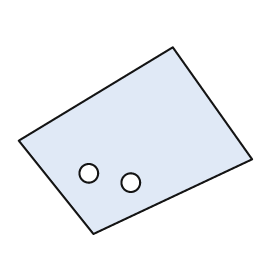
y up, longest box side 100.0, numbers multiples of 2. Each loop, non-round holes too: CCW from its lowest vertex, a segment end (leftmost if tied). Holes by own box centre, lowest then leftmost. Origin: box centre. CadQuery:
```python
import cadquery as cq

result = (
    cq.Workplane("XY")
    .moveTo(-18.0, -40.0)
    .lineTo(50.0, -8.0)
    .lineTo(16.0, 40.0)
    .lineTo(-50.0, 0.0)
    .close()
    .moveTo(-2.0, -18.0)
    .circle(4.0)
    .moveTo(-20.0, -14.0)
    .circle(4.0)
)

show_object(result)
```